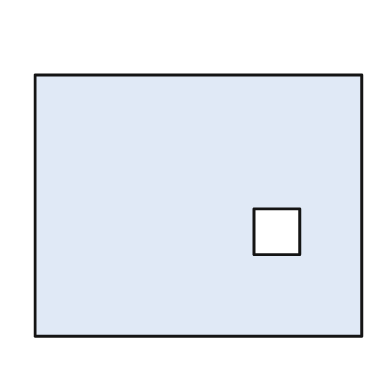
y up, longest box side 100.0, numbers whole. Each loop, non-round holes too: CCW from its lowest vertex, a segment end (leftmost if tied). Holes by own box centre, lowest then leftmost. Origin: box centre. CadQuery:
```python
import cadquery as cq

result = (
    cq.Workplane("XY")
    .moveTo(-50.0, -40.0)
    .lineTo(50.0, -40.0)
    .lineTo(50.0, 40.0)
    .lineTo(-50.0, 40.0)
    .close()
    .moveTo(17.0, -15.0)
    .lineTo(31.0, -15.0)
    .lineTo(31.0, -1.0)
    .lineTo(17.0, -1.0)
    .close()
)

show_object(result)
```